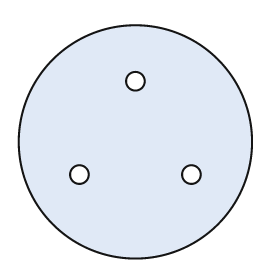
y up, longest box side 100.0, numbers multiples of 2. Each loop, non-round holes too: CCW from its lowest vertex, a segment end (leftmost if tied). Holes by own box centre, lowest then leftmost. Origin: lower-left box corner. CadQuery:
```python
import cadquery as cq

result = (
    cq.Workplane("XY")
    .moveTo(50.0, 50.0)
    .circle(50.0)
    .moveTo(26.0, 36.0)
    .circle(4.0)
    .moveTo(74.0, 36.0)
    .circle(4.0)
    .moveTo(50.0, 76.0)
    .circle(4.0)
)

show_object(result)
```